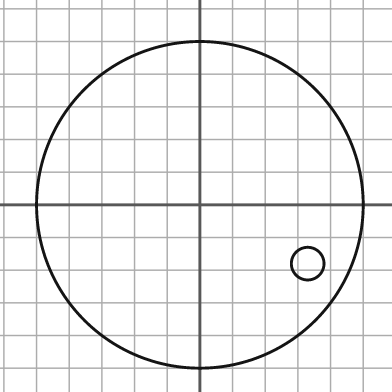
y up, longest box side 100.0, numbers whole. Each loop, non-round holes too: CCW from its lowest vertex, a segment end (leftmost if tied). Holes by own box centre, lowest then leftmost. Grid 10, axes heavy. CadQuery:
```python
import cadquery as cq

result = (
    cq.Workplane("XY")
    .moveTo(0.0, 0.0)
    .circle(50.0)
    .moveTo(33.0, -18.0)
    .circle(5.0)
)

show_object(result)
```